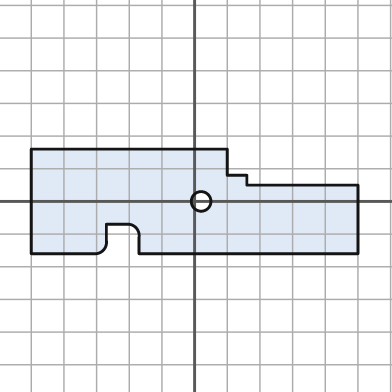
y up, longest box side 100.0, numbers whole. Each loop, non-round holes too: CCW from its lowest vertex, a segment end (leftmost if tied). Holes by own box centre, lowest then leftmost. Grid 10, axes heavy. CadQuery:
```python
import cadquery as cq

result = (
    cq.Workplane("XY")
    .moveTo(-50.0, -16.0)
    .lineTo(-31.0, -16.0)
    .threePointArc((-28.0, -15.0), (-27.0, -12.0))
    .lineTo(-27.0, -7.0)
    .lineTo(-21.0, -7.0)
    .threePointArc((-18.0, -8.0), (-17.0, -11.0))
    .lineTo(-17.0, -16.0)
    .lineTo(50.0, -16.0)
    .lineTo(50.0, 5.0)
    .lineTo(16.0, 5.0)
    .lineTo(16.0, 8.0)
    .lineTo(10.0, 8.0)
    .lineTo(10.0, 16.0)
    .lineTo(-50.0, 16.0)
    .close()
    .moveTo(2.0, 0.0)
    .circle(3.0)
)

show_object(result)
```